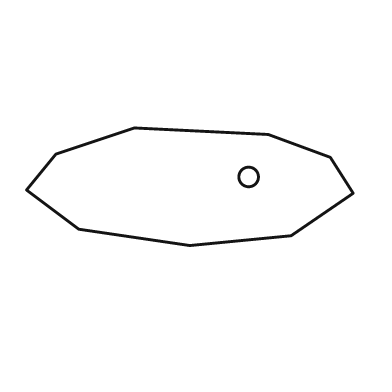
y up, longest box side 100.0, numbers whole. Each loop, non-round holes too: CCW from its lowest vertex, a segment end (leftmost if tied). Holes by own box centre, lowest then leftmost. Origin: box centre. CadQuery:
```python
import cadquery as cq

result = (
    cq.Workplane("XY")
    .moveTo(0.0, -18.0)
    .lineTo(31.0, -15.0)
    .lineTo(50.0, -2.0)
    .lineTo(43.0, 9.0)
    .lineTo(24.0, 16.0)
    .lineTo(-17.0, 18.0)
    .lineTo(-41.0, 10.0)
    .lineTo(-50.0, -1.0)
    .lineTo(-34.0, -13.0)
    .close()
    .moveTo(18.0, 3.0)
    .circle(3.0)
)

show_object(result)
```